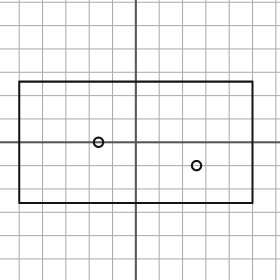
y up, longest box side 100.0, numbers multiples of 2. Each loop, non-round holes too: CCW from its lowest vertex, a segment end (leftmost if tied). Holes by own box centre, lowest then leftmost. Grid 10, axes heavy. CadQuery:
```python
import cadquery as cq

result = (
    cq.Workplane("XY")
    .moveTo(-50.0, -26.0)
    .lineTo(50.0, -26.0)
    .lineTo(50.0, 26.0)
    .lineTo(-50.0, 26.0)
    .close()
    .moveTo(26.0, -10.0)
    .circle(2.0)
    .moveTo(-16.0, 0.0)
    .circle(2.0)
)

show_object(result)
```